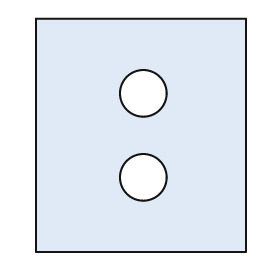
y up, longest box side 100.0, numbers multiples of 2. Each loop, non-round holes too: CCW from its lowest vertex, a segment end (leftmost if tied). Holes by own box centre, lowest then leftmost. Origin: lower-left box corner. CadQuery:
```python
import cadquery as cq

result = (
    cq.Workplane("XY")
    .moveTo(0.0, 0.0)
    .lineTo(90.0, 0.0)
    .lineTo(90.0, 100.0)
    .lineTo(0.0, 100.0)
    .close()
    .moveTo(46.0, 32.0)
    .circle(10.0)
    .moveTo(46.0, 68.0)
    .circle(10.0)
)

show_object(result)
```